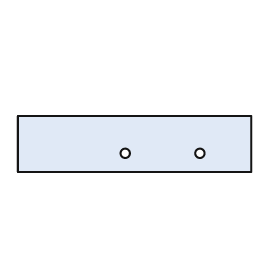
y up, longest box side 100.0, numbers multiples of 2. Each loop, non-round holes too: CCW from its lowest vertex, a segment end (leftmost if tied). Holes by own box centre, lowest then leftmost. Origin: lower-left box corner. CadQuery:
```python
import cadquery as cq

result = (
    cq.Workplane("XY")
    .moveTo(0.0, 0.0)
    .lineTo(100.0, 0.0)
    .lineTo(100.0, 24.0)
    .lineTo(0.0, 24.0)
    .close()
    .moveTo(46.0, 8.0)
    .circle(2.0)
    .moveTo(78.0, 8.0)
    .circle(2.0)
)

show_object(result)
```